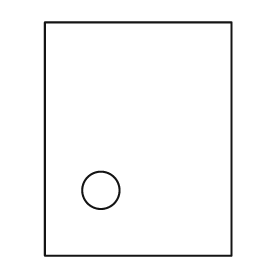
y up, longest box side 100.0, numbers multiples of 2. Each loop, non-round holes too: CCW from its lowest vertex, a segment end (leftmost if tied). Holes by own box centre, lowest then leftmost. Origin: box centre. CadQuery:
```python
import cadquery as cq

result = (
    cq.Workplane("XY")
    .moveTo(-40.0, -50.0)
    .lineTo(40.0, -50.0)
    .lineTo(40.0, 50.0)
    .lineTo(-40.0, 50.0)
    .close()
    .moveTo(-16.0, -22.0)
    .circle(8.0)
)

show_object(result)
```